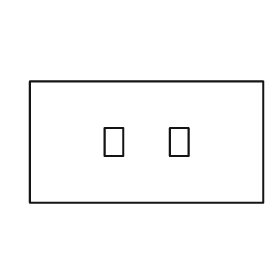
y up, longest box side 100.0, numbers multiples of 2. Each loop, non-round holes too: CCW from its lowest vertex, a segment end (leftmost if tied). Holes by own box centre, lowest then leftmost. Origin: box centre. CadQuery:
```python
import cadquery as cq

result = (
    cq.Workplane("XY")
    .moveTo(-50.0, -26.0)
    .lineTo(50.0, -26.0)
    .lineTo(50.0, 26.0)
    .lineTo(-50.0, 26.0)
    .close()
    .moveTo(-18.0, -6.0)
    .lineTo(-10.0, -6.0)
    .lineTo(-10.0, 6.0)
    .lineTo(-18.0, 6.0)
    .close()
    .moveTo(10.0, -6.0)
    .lineTo(18.0, -6.0)
    .lineTo(18.0, 6.0)
    .lineTo(10.0, 6.0)
    .close()
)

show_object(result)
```